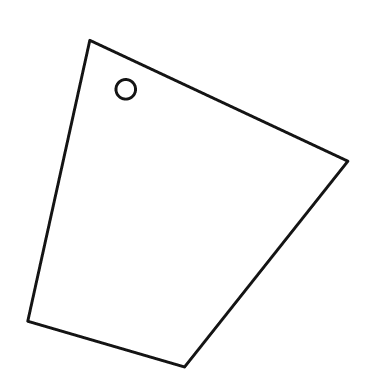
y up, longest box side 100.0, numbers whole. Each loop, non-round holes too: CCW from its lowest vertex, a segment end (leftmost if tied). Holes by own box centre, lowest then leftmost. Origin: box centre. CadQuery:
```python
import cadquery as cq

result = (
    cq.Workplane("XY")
    .moveTo(-1.0, -50.0)
    .lineTo(49.0, 13.0)
    .lineTo(-30.0, 50.0)
    .lineTo(-49.0, -36.0)
    .close()
    .moveTo(-19.0, 35.0)
    .circle(3.0)
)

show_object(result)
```